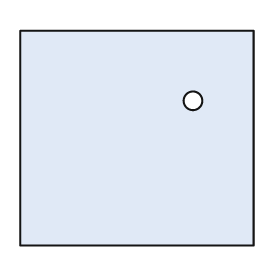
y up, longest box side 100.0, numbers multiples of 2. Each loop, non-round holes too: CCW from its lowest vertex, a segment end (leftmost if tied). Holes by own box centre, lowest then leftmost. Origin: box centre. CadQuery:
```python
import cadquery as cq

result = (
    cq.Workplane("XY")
    .moveTo(-50.0, -46.0)
    .lineTo(50.0, -46.0)
    .lineTo(50.0, 46.0)
    .lineTo(-50.0, 46.0)
    .close()
    .moveTo(24.0, 16.0)
    .circle(4.0)
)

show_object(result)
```